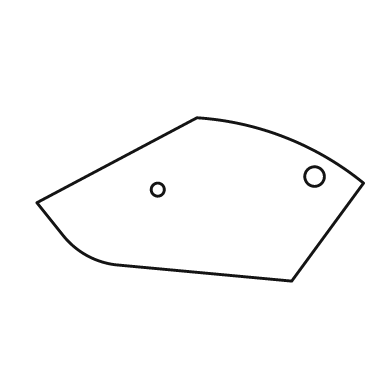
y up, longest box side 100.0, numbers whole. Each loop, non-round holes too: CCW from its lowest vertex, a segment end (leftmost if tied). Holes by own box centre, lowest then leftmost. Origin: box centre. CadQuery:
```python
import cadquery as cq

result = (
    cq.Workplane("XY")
    .moveTo(28.0, -25.0)
    .lineTo(50.0, 5.0)
    .threePointArc((26.0, 19.0), (-1.0, 25.0))
    .lineTo(-50.0, -1.0)
    .lineTo(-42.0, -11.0)
    .threePointArc((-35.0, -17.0), (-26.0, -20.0))
    .close()
    .moveTo(-13.0, 3.0)
    .circle(2.0)
    .moveTo(35.0, 7.0)
    .circle(3.0)
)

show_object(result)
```